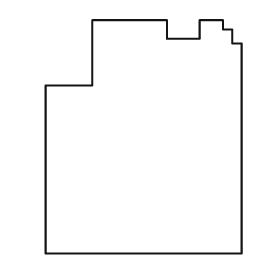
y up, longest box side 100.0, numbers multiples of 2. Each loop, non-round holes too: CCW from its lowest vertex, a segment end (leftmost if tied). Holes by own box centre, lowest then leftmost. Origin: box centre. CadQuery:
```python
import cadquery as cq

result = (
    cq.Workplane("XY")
    .moveTo(-42.0, -50.0)
    .lineTo(42.0, -50.0)
    .lineTo(42.0, 40.0)
    .lineTo(38.0, 40.0)
    .lineTo(38.0, 46.0)
    .lineTo(34.0, 46.0)
    .lineTo(34.0, 50.0)
    .lineTo(24.0, 50.0)
    .lineTo(24.0, 42.0)
    .lineTo(10.0, 42.0)
    .lineTo(10.0, 50.0)
    .lineTo(-22.0, 50.0)
    .lineTo(-22.0, 22.0)
    .lineTo(-42.0, 22.0)
    .close()
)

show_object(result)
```